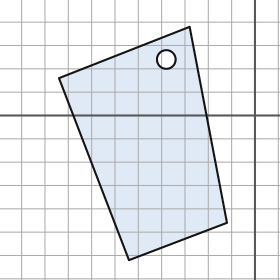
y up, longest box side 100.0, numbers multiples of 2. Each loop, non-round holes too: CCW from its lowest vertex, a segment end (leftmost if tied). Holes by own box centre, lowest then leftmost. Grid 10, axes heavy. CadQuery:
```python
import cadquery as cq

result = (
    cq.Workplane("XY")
    .moveTo(-54.0, -62.0)
    .lineTo(-12.0, -46.0)
    .lineTo(-28.0, 38.0)
    .lineTo(-84.0, 16.0)
    .close()
    .moveTo(-38.0, 24.0)
    .circle(4.0)
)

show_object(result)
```